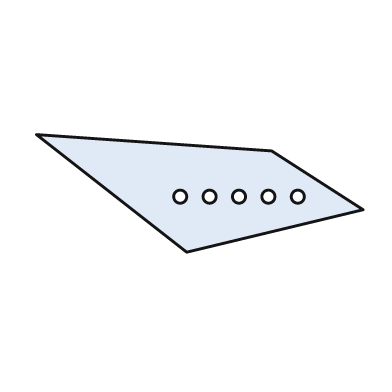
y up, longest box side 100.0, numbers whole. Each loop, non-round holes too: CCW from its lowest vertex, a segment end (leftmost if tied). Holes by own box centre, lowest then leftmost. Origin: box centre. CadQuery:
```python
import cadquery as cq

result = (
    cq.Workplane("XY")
    .moveTo(-4.0, -18.0)
    .lineTo(50.0, -5.0)
    .lineTo(22.0, 13.0)
    .lineTo(-50.0, 18.0)
    .close()
    .moveTo(-6.0, -1.0)
    .circle(2.0)
    .moveTo(3.0, -1.0)
    .circle(2.0)
    .moveTo(12.0, -1.0)
    .circle(2.0)
    .moveTo(21.0, -1.0)
    .circle(2.0)
    .moveTo(30.0, -1.0)
    .circle(2.0)
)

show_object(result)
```